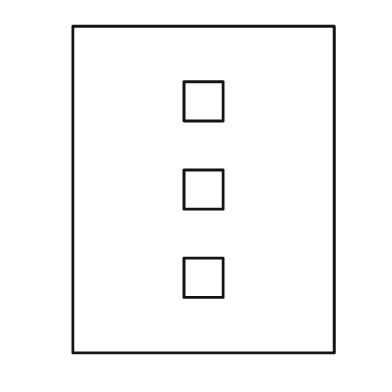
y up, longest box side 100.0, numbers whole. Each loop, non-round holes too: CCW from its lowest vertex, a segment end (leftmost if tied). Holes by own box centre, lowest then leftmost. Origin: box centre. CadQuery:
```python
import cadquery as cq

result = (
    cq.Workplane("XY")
    .moveTo(-40.0, -50.0)
    .lineTo(40.0, -50.0)
    .lineTo(40.0, 50.0)
    .lineTo(-40.0, 50.0)
    .close()
    .moveTo(-6.0, -33.0)
    .lineTo(6.0, -33.0)
    .lineTo(6.0, -21.0)
    .lineTo(-6.0, -21.0)
    .close()
    .moveTo(-6.0, -6.0)
    .lineTo(6.0, -6.0)
    .lineTo(6.0, 6.0)
    .lineTo(-6.0, 6.0)
    .close()
    .moveTo(-6.0, 21.0)
    .lineTo(6.0, 21.0)
    .lineTo(6.0, 33.0)
    .lineTo(-6.0, 33.0)
    .close()
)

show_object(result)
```